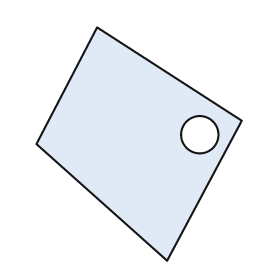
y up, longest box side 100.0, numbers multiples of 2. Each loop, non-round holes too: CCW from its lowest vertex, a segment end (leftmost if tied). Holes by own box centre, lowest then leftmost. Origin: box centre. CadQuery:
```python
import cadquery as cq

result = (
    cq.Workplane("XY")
    .moveTo(12.0, -50.0)
    .lineTo(44.0, 10.0)
    .lineTo(-18.0, 50.0)
    .lineTo(-44.0, 0.0)
    .close()
    .moveTo(26.0, 4.0)
    .circle(8.0)
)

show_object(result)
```